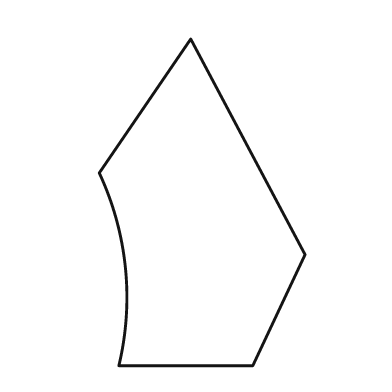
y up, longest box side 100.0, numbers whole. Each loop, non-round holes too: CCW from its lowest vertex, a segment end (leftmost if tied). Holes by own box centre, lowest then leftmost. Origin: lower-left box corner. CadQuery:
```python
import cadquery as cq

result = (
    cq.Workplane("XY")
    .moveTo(6.0, 0.0)
    .lineTo(47.0, 0.0)
    .lineTo(63.0, 34.0)
    .lineTo(28.0, 100.0)
    .lineTo(0.0, 59.0)
    .threePointArc((8.0, 30.0), (6.0, 0.0))
    .close()
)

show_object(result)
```